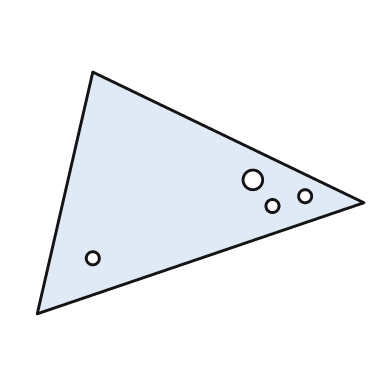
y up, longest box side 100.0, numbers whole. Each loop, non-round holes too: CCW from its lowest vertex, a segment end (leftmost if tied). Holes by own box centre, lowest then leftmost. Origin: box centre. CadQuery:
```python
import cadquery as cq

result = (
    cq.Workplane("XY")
    .moveTo(-50.0, -37.0)
    .lineTo(50.0, -3.0)
    .lineTo(-33.0, 37.0)
    .close()
    .moveTo(-33.0, -20.0)
    .circle(2.0)
    .moveTo(22.0, -4.0)
    .circle(2.0)
    .moveTo(32.0, -1.0)
    .circle(2.0)
    .moveTo(16.0, 4.0)
    .circle(3.0)
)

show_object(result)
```